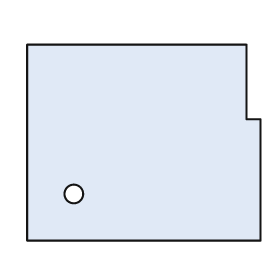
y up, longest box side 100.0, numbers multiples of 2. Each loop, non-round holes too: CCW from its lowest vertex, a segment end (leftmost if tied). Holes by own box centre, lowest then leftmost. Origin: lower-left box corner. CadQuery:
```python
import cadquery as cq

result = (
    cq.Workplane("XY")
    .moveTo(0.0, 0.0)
    .lineTo(100.0, 0.0)
    .lineTo(100.0, 52.0)
    .lineTo(94.0, 52.0)
    .lineTo(94.0, 84.0)
    .lineTo(0.0, 84.0)
    .close()
    .moveTo(20.0, 20.0)
    .circle(4.0)
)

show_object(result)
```